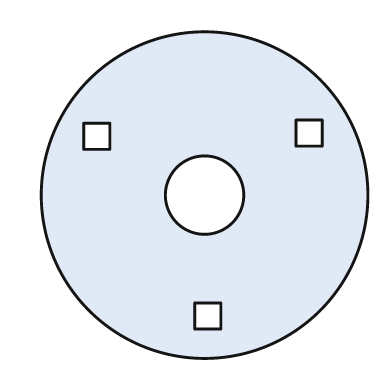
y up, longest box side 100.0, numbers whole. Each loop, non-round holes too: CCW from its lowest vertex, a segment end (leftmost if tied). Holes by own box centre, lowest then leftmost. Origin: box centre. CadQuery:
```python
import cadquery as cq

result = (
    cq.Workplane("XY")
    .moveTo(0.0, 0.0)
    .circle(50.0)
    .moveTo(-3.0, -41.0)
    .lineTo(5.0, -41.0)
    .lineTo(5.0, -33.0)
    .lineTo(-3.0, -33.0)
    .close()
    .moveTo(0.0, 0.0)
    .circle(12.0)
    .moveTo(-37.0, 14.0)
    .lineTo(-29.0, 14.0)
    .lineTo(-29.0, 22.0)
    .lineTo(-37.0, 22.0)
    .close()
    .moveTo(28.0, 15.0)
    .lineTo(36.0, 15.0)
    .lineTo(36.0, 23.0)
    .lineTo(28.0, 23.0)
    .close()
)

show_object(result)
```